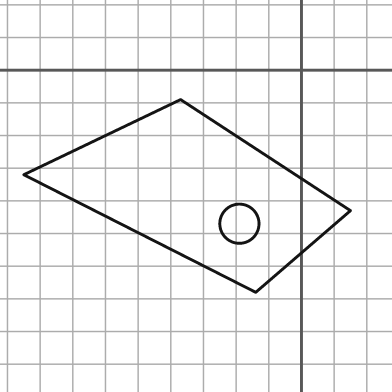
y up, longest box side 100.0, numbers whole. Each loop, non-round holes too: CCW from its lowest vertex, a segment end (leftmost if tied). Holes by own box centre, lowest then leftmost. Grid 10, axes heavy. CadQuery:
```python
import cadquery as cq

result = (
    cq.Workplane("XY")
    .moveTo(-14.0, -68.0)
    .lineTo(15.0, -43.0)
    .lineTo(-37.0, -9.0)
    .lineTo(-85.0, -32.0)
    .close()
    .moveTo(-19.0, -47.0)
    .circle(6.0)
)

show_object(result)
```